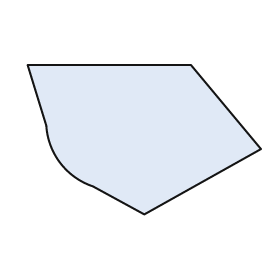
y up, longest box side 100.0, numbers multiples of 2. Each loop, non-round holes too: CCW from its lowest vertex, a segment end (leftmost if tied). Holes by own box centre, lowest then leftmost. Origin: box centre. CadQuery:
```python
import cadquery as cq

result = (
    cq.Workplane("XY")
    .moveTo(0.0, -32.0)
    .lineTo(50.0, -4.0)
    .lineTo(20.0, 32.0)
    .lineTo(-50.0, 32.0)
    .lineTo(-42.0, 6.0)
    .threePointArc((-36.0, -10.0), (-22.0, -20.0))
    .close()
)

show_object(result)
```